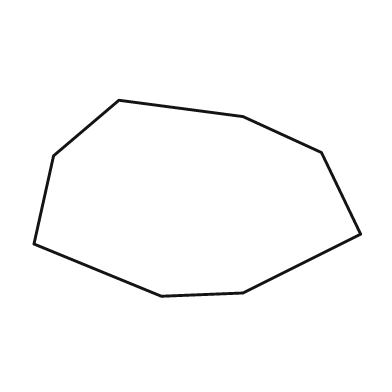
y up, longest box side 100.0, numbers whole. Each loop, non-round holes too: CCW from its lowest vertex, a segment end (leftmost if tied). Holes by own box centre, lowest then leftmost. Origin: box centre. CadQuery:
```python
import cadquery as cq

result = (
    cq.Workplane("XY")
    .moveTo(-11.0, -30.0)
    .lineTo(14.0, -29.0)
    .lineTo(50.0, -11.0)
    .lineTo(38.0, 14.0)
    .lineTo(14.0, 25.0)
    .lineTo(-24.0, 30.0)
    .lineTo(-44.0, 13.0)
    .lineTo(-50.0, -14.0)
    .close()
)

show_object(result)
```